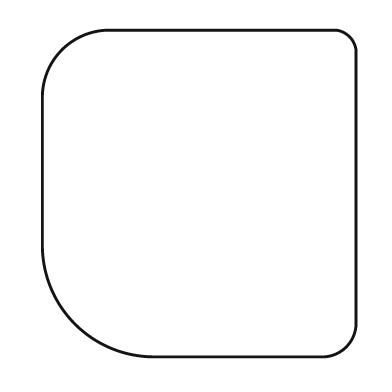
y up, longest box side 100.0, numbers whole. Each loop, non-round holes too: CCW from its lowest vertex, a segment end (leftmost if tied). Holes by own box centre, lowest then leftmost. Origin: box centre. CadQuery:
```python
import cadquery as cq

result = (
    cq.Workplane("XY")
    .moveTo(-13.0, -50.0)
    .lineTo(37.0, -50.0)
    .threePointArc((45.0, -47.0), (48.0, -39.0))
    .lineTo(48.0, 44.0)
    .threePointArc((46.0, 48.0), (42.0, 50.0))
    .lineTo(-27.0, 50.0)
    .threePointArc((-42.0, 44.0), (-48.0, 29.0))
    .lineTo(-48.0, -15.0)
    .threePointArc((-38.0, -40.0), (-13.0, -50.0))
    .close()
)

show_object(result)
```